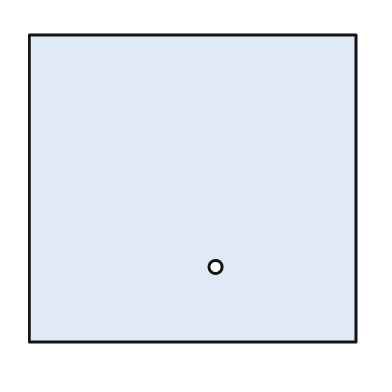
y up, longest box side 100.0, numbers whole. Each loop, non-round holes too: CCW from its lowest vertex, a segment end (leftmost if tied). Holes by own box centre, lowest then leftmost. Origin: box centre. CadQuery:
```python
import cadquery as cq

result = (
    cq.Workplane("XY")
    .moveTo(-50.0, -47.0)
    .lineTo(50.0, -47.0)
    .lineTo(50.0, 47.0)
    .lineTo(-50.0, 47.0)
    .close()
    .moveTo(7.0, -24.0)
    .circle(2.0)
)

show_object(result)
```